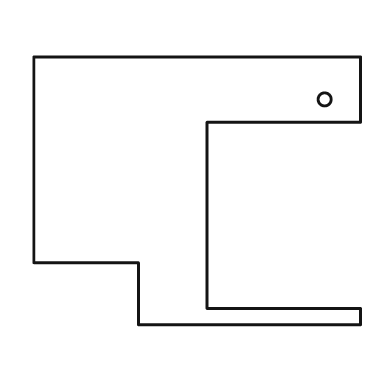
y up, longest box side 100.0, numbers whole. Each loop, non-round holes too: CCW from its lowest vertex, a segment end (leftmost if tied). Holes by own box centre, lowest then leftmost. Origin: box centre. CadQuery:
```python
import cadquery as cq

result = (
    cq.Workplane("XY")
    .moveTo(-18.0, -41.0)
    .lineTo(50.0, -41.0)
    .lineTo(50.0, -36.0)
    .lineTo(3.0, -36.0)
    .lineTo(3.0, 21.0)
    .lineTo(50.0, 21.0)
    .lineTo(50.0, 41.0)
    .lineTo(-50.0, 41.0)
    .lineTo(-50.0, -22.0)
    .lineTo(-18.0, -22.0)
    .close()
    .moveTo(39.0, 28.0)
    .circle(2.0)
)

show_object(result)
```